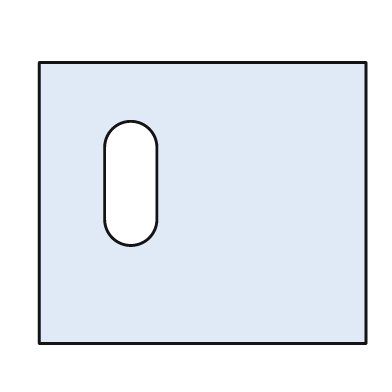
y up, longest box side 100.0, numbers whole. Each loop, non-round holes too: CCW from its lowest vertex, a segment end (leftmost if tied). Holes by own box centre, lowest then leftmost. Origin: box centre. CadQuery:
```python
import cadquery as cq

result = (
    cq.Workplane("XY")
    .moveTo(-50.0, -43.0)
    .lineTo(50.0, -43.0)
    .lineTo(50.0, 43.0)
    .lineTo(-50.0, 43.0)
    .close()
    .moveTo(-30.0, -5.0)
    .threePointArc((-22.0, -13.0), (-14.0, -5.0))
    .lineTo(-14.0, 17.0)
    .threePointArc((-22.0, 25.0), (-30.0, 17.0))
    .close()
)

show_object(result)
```